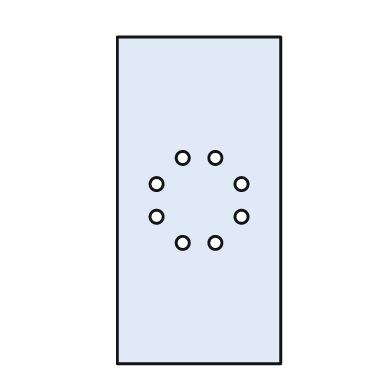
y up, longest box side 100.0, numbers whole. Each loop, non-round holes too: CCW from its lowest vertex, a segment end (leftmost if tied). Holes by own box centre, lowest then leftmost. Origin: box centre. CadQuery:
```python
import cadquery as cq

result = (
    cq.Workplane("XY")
    .moveTo(-25.0, -50.0)
    .lineTo(25.0, -50.0)
    .lineTo(25.0, 50.0)
    .lineTo(-25.0, 50.0)
    .close()
    .moveTo(-5.0, -13.0)
    .circle(2.0)
    .moveTo(5.0, -13.0)
    .circle(2.0)
    .moveTo(-13.0, -5.0)
    .circle(2.0)
    .moveTo(13.0, -5.0)
    .circle(2.0)
    .moveTo(-13.0, 5.0)
    .circle(2.0)
    .moveTo(13.0, 5.0)
    .circle(2.0)
    .moveTo(-5.0, 13.0)
    .circle(2.0)
    .moveTo(5.0, 13.0)
    .circle(2.0)
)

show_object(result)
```